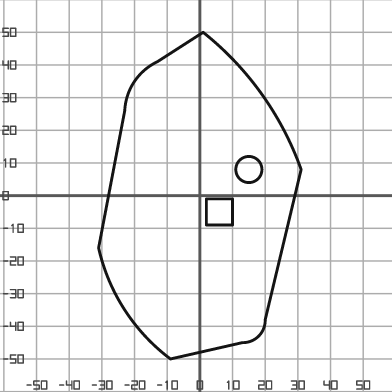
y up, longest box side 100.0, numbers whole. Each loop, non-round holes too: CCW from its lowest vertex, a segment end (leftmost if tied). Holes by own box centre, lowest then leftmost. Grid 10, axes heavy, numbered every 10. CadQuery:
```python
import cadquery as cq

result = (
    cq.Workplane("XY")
    .moveTo(-9.0, -50.0)
    .lineTo(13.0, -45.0)
    .threePointArc((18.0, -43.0), (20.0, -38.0))
    .lineTo(31.0, 8.0)
    .threePointArc((19.0, 31.0), (1.0, 50.0))
    .lineTo(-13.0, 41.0)
    .threePointArc((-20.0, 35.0), (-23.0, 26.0))
    .lineTo(-31.0, -16.0)
    .threePointArc((-23.0, -35.0), (-9.0, -50.0))
    .close()
    .moveTo(2.0, -9.0)
    .lineTo(10.0, -9.0)
    .lineTo(10.0, -1.0)
    .lineTo(2.0, -1.0)
    .close()
    .moveTo(15.0, 8.0)
    .circle(4.0)
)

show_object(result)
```